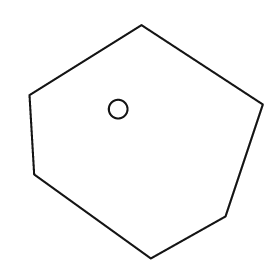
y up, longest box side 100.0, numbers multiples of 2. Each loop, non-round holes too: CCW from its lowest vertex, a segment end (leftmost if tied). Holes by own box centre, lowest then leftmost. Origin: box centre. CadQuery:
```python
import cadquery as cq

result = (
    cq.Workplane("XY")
    .moveTo(2.0, -50.0)
    .lineTo(34.0, -32.0)
    .lineTo(50.0, 16.0)
    .lineTo(-2.0, 50.0)
    .lineTo(-50.0, 20.0)
    .lineTo(-48.0, -14.0)
    .close()
    .moveTo(-12.0, 14.0)
    .circle(4.0)
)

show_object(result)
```